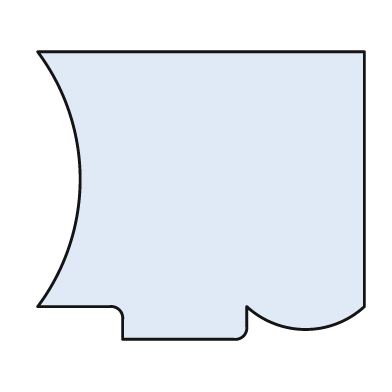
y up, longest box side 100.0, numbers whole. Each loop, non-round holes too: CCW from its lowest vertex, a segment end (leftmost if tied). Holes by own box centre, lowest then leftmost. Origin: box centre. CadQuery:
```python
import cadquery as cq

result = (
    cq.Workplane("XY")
    .moveTo(-24.0, -44.0)
    .lineTo(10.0, -44.0)
    .threePointArc((13.0, -43.0), (14.0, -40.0))
    .lineTo(14.0, -34.0)
    .threePointArc((32.0, -41.0), (50.0, -34.0))
    .lineTo(50.0, 44.0)
    .lineTo(-50.0, 44.0)
    .threePointArc((-37.0, 5.0), (-50.0, -34.0))
    .lineTo(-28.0, -34.0)
    .threePointArc((-25.0, -35.0), (-24.0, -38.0))
    .close()
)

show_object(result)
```